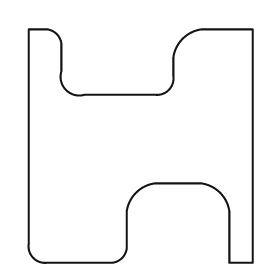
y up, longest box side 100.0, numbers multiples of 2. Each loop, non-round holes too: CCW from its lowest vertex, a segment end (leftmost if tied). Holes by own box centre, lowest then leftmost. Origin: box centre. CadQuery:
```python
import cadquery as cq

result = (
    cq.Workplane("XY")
    .moveTo(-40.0, -50.0)
    .lineTo(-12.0, -50.0)
    .threePointArc((-8.0, -48.0), (-6.0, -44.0))
    .lineTo(-6.0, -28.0)
    .threePointArc((-2.0, -20.0), (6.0, -16.0))
    .lineTo(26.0, -16.0)
    .threePointArc((34.0, -20.0), (38.0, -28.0))
    .lineTo(38.0, -50.0)
    .lineTo(48.0, -50.0)
    .lineTo(48.0, 50.0)
    .lineTo(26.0, 50.0)
    .threePointArc((18.0, 46.0), (14.0, 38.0))
    .lineTo(14.0, 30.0)
    .threePointArc((12.0, 24.0), (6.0, 22.0))
    .lineTo(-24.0, 22.0)
    .threePointArc((-32.0, 24.0), (-34.0, 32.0))
    .lineTo(-34.0, 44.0)
    .threePointArc((-36.0, 48.0), (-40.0, 50.0))
    .lineTo(-48.0, 50.0)
    .lineTo(-48.0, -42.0)
    .threePointArc((-46.0, -48.0), (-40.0, -50.0))
    .close()
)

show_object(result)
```